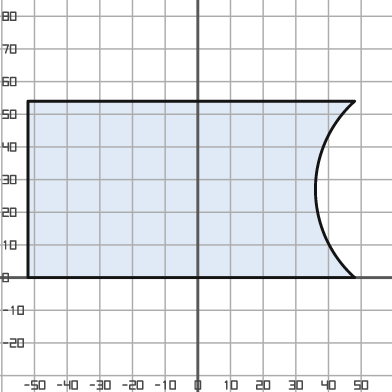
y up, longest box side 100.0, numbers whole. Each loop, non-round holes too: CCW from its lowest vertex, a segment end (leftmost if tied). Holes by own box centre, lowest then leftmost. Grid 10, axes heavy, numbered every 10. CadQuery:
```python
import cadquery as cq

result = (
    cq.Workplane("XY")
    .moveTo(-52.0, 0.0)
    .lineTo(48.0, 0.0)
    .threePointArc((36.0, 27.0), (48.0, 54.0))
    .lineTo(-52.0, 54.0)
    .close()
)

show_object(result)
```